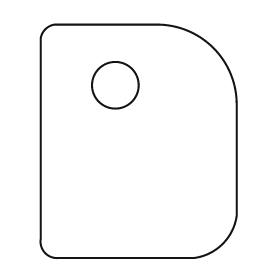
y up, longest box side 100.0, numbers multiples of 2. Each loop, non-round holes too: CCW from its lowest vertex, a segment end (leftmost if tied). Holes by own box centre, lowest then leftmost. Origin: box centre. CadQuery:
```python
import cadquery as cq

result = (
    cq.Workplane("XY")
    .moveTo(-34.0, -50.0)
    .lineTo(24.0, -50.0)
    .threePointArc((36.0, -44.0), (42.0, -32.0))
    .lineTo(42.0, 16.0)
    .threePointArc((32.0, 40.0), (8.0, 50.0))
    .lineTo(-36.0, 50.0)
    .threePointArc((-40.0, 48.0), (-42.0, 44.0))
    .lineTo(-42.0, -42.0)
    .threePointArc((-40.0, -48.0), (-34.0, -50.0))
    .close()
    .moveTo(-10.0, 24.0)
    .circle(10.0)
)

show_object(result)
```